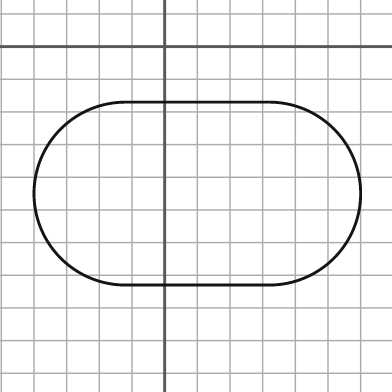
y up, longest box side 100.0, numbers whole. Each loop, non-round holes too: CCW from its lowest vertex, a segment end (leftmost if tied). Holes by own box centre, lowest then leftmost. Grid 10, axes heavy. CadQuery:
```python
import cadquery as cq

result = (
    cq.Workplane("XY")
    .moveTo(-12.0, -73.0)
    .lineTo(32.0, -73.0)
    .threePointArc((60.0, -45.0), (32.0, -17.0))
    .lineTo(-12.0, -17.0)
    .threePointArc((-40.0, -45.0), (-12.0, -73.0))
    .close()
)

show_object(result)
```